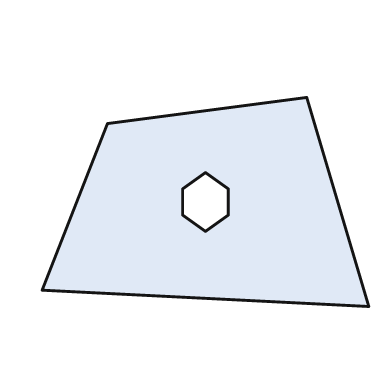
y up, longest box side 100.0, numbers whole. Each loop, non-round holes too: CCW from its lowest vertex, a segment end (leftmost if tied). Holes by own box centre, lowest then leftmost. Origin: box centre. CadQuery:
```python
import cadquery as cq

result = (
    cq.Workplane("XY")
    .moveTo(50.0, -32.0)
    .lineTo(31.0, 32.0)
    .lineTo(-30.0, 24.0)
    .lineTo(-50.0, -27.0)
    .close()
    .moveTo(0.0, -9.0)
    .lineTo(7.0, -4.0)
    .lineTo(7.0, 4.0)
    .lineTo(0.0, 9.0)
    .lineTo(-7.0, 4.0)
    .lineTo(-7.0, -4.0)
    .close()
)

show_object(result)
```